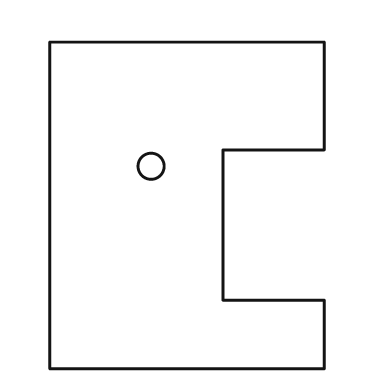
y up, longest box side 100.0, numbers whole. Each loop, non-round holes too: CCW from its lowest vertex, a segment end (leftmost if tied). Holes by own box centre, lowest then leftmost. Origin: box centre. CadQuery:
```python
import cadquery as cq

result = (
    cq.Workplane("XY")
    .moveTo(-42.0, -50.0)
    .lineTo(42.0, -50.0)
    .lineTo(42.0, -29.0)
    .lineTo(11.0, -29.0)
    .lineTo(11.0, 17.0)
    .lineTo(42.0, 17.0)
    .lineTo(42.0, 50.0)
    .lineTo(-42.0, 50.0)
    .close()
    .moveTo(-11.0, 12.0)
    .circle(4.0)
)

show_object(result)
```